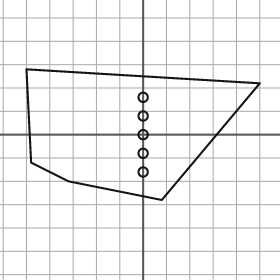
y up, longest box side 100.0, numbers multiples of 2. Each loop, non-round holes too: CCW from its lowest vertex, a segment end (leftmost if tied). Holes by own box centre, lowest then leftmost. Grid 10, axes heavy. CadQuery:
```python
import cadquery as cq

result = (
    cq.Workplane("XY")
    .moveTo(8.0, -28.0)
    .lineTo(50.0, 22.0)
    .lineTo(-50.0, 28.0)
    .lineTo(-48.0, -12.0)
    .lineTo(-32.0, -20.0)
    .close()
    .moveTo(0.0, -16.0)
    .circle(2.0)
    .moveTo(0.0, -8.0)
    .circle(2.0)
    .moveTo(0.0, 0.0)
    .circle(2.0)
    .moveTo(0.0, 8.0)
    .circle(2.0)
    .moveTo(0.0, 16.0)
    .circle(2.0)
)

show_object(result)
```